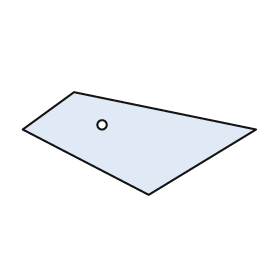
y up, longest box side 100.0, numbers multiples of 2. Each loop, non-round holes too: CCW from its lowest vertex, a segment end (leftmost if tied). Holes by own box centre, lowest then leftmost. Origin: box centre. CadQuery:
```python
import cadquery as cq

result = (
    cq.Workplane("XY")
    .moveTo(4.0, -22.0)
    .lineTo(50.0, 6.0)
    .lineTo(-28.0, 22.0)
    .lineTo(-50.0, 6.0)
    .close()
    .moveTo(-16.0, 8.0)
    .circle(2.0)
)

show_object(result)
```